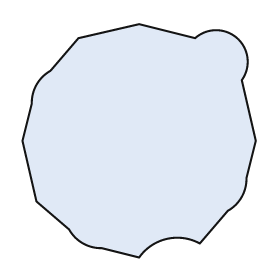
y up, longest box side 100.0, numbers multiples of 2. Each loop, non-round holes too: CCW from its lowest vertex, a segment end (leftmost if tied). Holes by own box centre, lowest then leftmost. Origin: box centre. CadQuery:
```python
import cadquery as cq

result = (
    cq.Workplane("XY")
    .moveTo(0.0, -50.0)
    .threePointArc((12.0, -42.0), (26.0, -44.0))
    .lineTo(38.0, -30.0)
    .threePointArc((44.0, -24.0), (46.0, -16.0))
    .lineTo(50.0, 0.0)
    .lineTo(44.0, 26.0)
    .threePointArc((42.0, 44.0), (24.0, 44.0))
    .lineTo(0.0, 50.0)
    .lineTo(-26.0, 44.0)
    .lineTo(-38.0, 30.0)
    .threePointArc((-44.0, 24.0), (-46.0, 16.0))
    .lineTo(-50.0, 0.0)
    .lineTo(-44.0, -26.0)
    .lineTo(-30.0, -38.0)
    .threePointArc((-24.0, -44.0), (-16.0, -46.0))
    .close()
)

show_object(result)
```